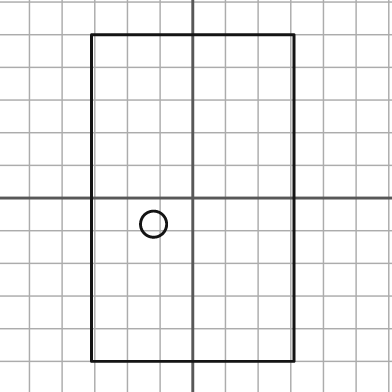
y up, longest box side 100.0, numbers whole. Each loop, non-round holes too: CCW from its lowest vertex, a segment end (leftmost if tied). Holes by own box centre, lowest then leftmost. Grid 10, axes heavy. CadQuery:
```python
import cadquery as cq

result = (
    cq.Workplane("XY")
    .moveTo(-31.0, -50.0)
    .lineTo(31.0, -50.0)
    .lineTo(31.0, 50.0)
    .lineTo(-31.0, 50.0)
    .close()
    .moveTo(-12.0, -8.0)
    .circle(4.0)
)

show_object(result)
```